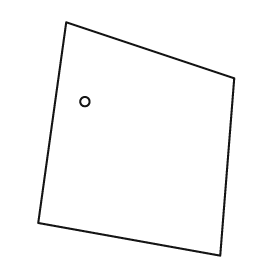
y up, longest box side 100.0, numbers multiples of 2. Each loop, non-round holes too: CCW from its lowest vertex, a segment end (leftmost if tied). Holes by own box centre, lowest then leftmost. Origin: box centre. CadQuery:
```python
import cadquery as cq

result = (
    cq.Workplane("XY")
    .moveTo(36.0, -50.0)
    .lineTo(42.0, 26.0)
    .lineTo(-30.0, 50.0)
    .lineTo(-42.0, -36.0)
    .close()
    .moveTo(-22.0, 16.0)
    .circle(2.0)
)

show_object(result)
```